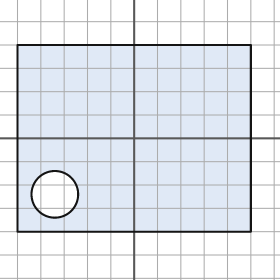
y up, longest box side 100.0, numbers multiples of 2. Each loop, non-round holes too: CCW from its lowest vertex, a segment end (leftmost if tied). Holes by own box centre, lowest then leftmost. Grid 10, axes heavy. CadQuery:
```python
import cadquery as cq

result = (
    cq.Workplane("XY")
    .moveTo(-50.0, -40.0)
    .lineTo(50.0, -40.0)
    .lineTo(50.0, 40.0)
    .lineTo(-50.0, 40.0)
    .close()
    .moveTo(-34.0, -24.0)
    .circle(10.0)
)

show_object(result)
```